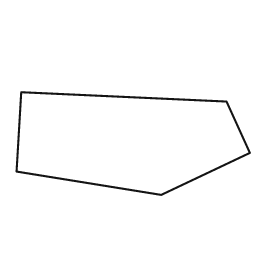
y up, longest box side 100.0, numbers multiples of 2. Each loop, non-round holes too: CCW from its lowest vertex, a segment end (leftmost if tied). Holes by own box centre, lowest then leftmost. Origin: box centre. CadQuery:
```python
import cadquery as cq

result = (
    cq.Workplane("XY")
    .moveTo(12.0, -22.0)
    .lineTo(50.0, -4.0)
    .lineTo(40.0, 18.0)
    .lineTo(-48.0, 22.0)
    .lineTo(-50.0, -12.0)
    .close()
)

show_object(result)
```